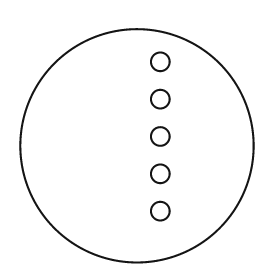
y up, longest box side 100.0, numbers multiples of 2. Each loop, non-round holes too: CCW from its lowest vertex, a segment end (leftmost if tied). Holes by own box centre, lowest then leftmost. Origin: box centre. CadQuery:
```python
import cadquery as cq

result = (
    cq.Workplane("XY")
    .moveTo(0.0, 0.0)
    .circle(50.0)
    .moveTo(10.0, -28.0)
    .circle(4.0)
    .moveTo(10.0, -12.0)
    .circle(4.0)
    .moveTo(10.0, 4.0)
    .circle(4.0)
    .moveTo(10.0, 20.0)
    .circle(4.0)
    .moveTo(10.0, 36.0)
    .circle(4.0)
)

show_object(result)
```